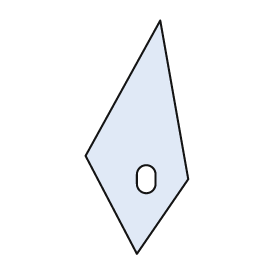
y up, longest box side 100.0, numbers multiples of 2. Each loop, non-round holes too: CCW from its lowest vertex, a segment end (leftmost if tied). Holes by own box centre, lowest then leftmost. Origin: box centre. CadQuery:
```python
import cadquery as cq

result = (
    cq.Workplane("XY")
    .moveTo(0.0, -50.0)
    .lineTo(22.0, -18.0)
    .lineTo(10.0, 50.0)
    .lineTo(-22.0, -8.0)
    .close()
    .moveTo(0.0, -20.0)
    .threePointArc((4.0, -24.0), (8.0, -20.0))
    .lineTo(8.0, -16.0)
    .threePointArc((4.0, -12.0), (0.0, -16.0))
    .close()
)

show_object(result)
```